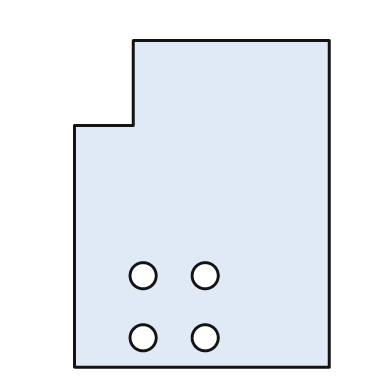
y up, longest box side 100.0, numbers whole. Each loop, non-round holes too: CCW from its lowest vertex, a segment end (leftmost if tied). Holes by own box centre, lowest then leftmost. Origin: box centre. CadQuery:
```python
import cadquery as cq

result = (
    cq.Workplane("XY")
    .moveTo(-39.0, -50.0)
    .lineTo(39.0, -50.0)
    .lineTo(39.0, 50.0)
    .lineTo(-21.0, 50.0)
    .lineTo(-21.0, 24.0)
    .lineTo(-39.0, 24.0)
    .close()
    .moveTo(-18.0, -41.0)
    .circle(4.0)
    .moveTo(1.0, -41.0)
    .circle(4.0)
    .moveTo(-18.0, -22.0)
    .circle(4.0)
    .moveTo(1.0, -22.0)
    .circle(4.0)
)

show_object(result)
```